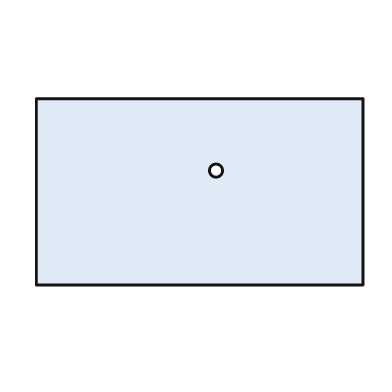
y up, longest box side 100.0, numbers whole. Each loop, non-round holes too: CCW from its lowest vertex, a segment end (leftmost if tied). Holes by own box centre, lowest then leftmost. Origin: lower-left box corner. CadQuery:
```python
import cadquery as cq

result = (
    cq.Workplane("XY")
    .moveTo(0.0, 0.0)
    .lineTo(100.0, 0.0)
    .lineTo(100.0, 57.0)
    .lineTo(0.0, 57.0)
    .close()
    .moveTo(55.0, 35.0)
    .circle(2.0)
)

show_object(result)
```